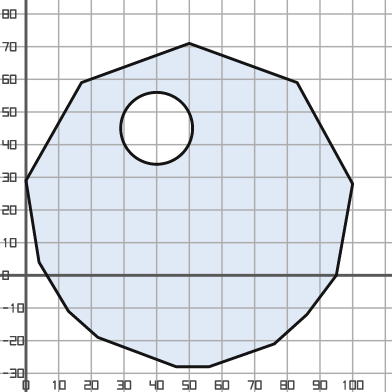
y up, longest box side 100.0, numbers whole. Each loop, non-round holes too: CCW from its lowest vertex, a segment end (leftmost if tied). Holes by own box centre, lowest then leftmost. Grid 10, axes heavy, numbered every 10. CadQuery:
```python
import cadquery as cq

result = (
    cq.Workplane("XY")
    .moveTo(46.0, -28.0)
    .lineTo(56.0, -28.0)
    .lineTo(76.0, -21.0)
    .lineTo(86.0, -12.0)
    .lineTo(95.0, 0.0)
    .lineTo(100.0, 28.0)
    .lineTo(83.0, 59.0)
    .lineTo(50.0, 71.0)
    .lineTo(17.0, 59.0)
    .lineTo(0.0, 29.0)
    .lineTo(4.0, 4.0)
    .lineTo(13.0, -11.0)
    .lineTo(22.0, -19.0)
    .close()
    .moveTo(40.0, 45.0)
    .circle(11.0)
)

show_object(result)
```